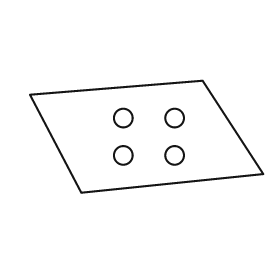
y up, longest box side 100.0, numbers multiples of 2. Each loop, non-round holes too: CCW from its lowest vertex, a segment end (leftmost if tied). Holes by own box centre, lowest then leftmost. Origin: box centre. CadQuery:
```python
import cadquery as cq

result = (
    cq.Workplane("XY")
    .moveTo(-28.0, -24.0)
    .lineTo(50.0, -16.0)
    .lineTo(24.0, 24.0)
    .lineTo(-50.0, 18.0)
    .close()
    .moveTo(-10.0, -8.0)
    .circle(4.0)
    .moveTo(12.0, -8.0)
    .circle(4.0)
    .moveTo(-10.0, 8.0)
    .circle(4.0)
    .moveTo(12.0, 8.0)
    .circle(4.0)
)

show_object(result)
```